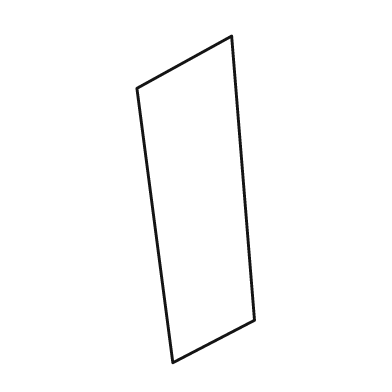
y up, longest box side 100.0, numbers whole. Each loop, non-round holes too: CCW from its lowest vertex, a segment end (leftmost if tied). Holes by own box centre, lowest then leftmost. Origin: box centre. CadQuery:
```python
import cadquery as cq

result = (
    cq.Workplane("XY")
    .moveTo(-7.0, -50.0)
    .lineTo(18.0, -37.0)
    .lineTo(11.0, 50.0)
    .lineTo(-18.0, 34.0)
    .close()
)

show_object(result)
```